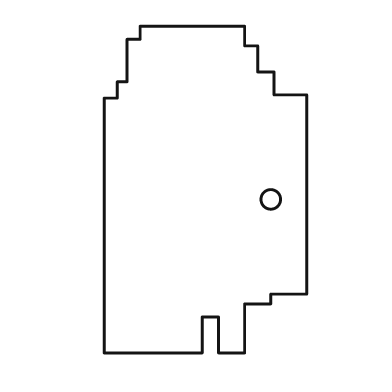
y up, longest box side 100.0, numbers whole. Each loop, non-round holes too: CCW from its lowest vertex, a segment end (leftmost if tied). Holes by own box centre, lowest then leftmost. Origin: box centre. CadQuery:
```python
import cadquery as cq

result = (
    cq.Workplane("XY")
    .moveTo(-31.0, -50.0)
    .lineTo(-1.0, -50.0)
    .lineTo(-1.0, -39.0)
    .lineTo(4.0, -39.0)
    .lineTo(4.0, -50.0)
    .lineTo(12.0, -50.0)
    .lineTo(12.0, -35.0)
    .lineTo(20.0, -35.0)
    .lineTo(20.0, -32.0)
    .lineTo(31.0, -32.0)
    .lineTo(31.0, 29.0)
    .lineTo(21.0, 29.0)
    .lineTo(21.0, 36.0)
    .lineTo(16.0, 36.0)
    .lineTo(16.0, 44.0)
    .lineTo(12.0, 44.0)
    .lineTo(12.0, 50.0)
    .lineTo(-20.0, 50.0)
    .lineTo(-20.0, 46.0)
    .lineTo(-24.0, 46.0)
    .lineTo(-24.0, 33.0)
    .lineTo(-27.0, 33.0)
    .lineTo(-27.0, 28.0)
    .lineTo(-31.0, 28.0)
    .close()
    .moveTo(20.0, -3.0)
    .circle(3.0)
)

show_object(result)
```